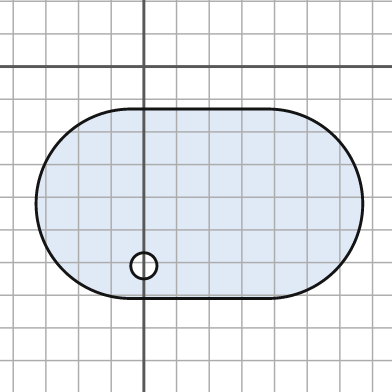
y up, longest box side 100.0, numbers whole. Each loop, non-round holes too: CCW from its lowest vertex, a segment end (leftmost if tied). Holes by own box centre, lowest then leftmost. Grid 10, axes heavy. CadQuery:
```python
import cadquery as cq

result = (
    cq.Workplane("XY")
    .moveTo(-4.0, -71.0)
    .lineTo(38.0, -71.0)
    .threePointArc((67.0, -42.0), (38.0, -13.0))
    .lineTo(-4.0, -13.0)
    .threePointArc((-33.0, -42.0), (-4.0, -71.0))
    .close()
    .moveTo(0.0, -61.0)
    .circle(4.0)
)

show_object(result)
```